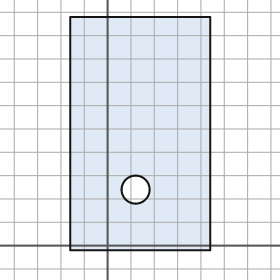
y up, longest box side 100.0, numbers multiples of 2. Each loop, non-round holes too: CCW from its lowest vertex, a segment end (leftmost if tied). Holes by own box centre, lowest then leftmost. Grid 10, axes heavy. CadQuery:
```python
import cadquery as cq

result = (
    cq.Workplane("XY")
    .moveTo(-16.0, -2.0)
    .lineTo(44.0, -2.0)
    .lineTo(44.0, 98.0)
    .lineTo(-16.0, 98.0)
    .close()
    .moveTo(12.0, 24.0)
    .circle(6.0)
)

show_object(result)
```